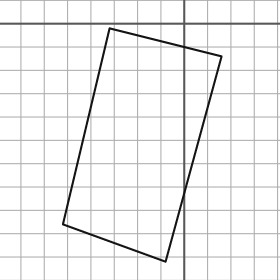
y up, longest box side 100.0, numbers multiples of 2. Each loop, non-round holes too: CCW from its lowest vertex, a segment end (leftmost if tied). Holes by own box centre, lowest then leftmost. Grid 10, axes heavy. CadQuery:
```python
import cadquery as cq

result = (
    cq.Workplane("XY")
    .moveTo(-8.0, -102.0)
    .lineTo(16.0, -14.0)
    .lineTo(-32.0, -2.0)
    .lineTo(-52.0, -86.0)
    .close()
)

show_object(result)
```